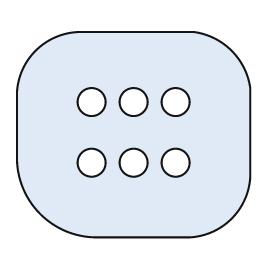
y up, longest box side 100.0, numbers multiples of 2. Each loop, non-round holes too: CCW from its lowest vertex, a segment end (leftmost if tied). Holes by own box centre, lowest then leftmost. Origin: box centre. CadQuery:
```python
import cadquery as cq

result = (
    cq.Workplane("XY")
    .moveTo(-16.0, -44.0)
    .lineTo(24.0, -44.0)
    .threePointArc((42.0, -36.0), (50.0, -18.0))
    .lineTo(50.0, 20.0)
    .threePointArc((42.0, 36.0), (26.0, 44.0))
    .lineTo(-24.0, 44.0)
    .threePointArc((-42.0, 36.0), (-50.0, 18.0))
    .lineTo(-50.0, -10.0)
    .threePointArc((-40.0, -34.0), (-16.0, -44.0))
    .close()
    .moveTo(-18.0, -12.0)
    .circle(6.0)
    .moveTo(0.0, -12.0)
    .circle(6.0)
    .moveTo(18.0, -12.0)
    .circle(6.0)
    .moveTo(-18.0, 14.0)
    .circle(6.0)
    .moveTo(0.0, 14.0)
    .circle(6.0)
    .moveTo(18.0, 14.0)
    .circle(6.0)
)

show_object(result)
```